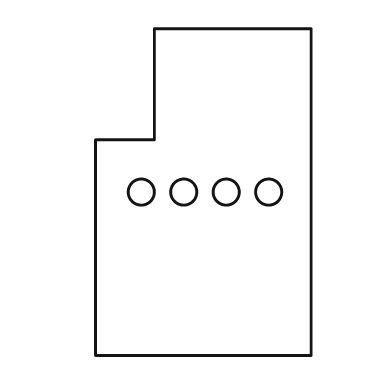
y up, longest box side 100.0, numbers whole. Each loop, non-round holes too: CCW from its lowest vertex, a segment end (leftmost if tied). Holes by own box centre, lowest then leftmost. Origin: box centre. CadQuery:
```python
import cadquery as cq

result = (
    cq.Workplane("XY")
    .moveTo(-33.0, -50.0)
    .lineTo(33.0, -50.0)
    .lineTo(33.0, 50.0)
    .lineTo(-15.0, 50.0)
    .lineTo(-15.0, 16.0)
    .lineTo(-33.0, 16.0)
    .close()
    .moveTo(-19.0, 0.0)
    .circle(4.0)
    .moveTo(-6.0, 0.0)
    .circle(4.0)
    .moveTo(7.0, 0.0)
    .circle(4.0)
    .moveTo(20.0, 0.0)
    .circle(4.0)
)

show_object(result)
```